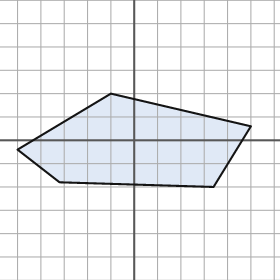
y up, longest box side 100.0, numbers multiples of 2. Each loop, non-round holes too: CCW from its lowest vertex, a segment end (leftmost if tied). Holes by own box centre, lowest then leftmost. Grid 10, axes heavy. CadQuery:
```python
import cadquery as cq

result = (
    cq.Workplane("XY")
    .moveTo(34.0, -20.0)
    .lineTo(50.0, 6.0)
    .lineTo(-10.0, 20.0)
    .lineTo(-50.0, -4.0)
    .lineTo(-32.0, -18.0)
    .close()
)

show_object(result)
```